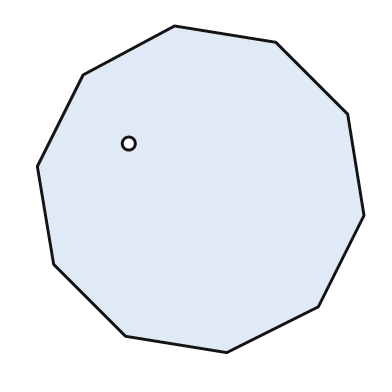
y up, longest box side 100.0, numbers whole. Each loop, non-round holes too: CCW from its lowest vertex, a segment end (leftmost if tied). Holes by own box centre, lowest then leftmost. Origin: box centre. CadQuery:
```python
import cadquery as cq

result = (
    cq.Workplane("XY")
    .moveTo(8.0, -50.0)
    .lineTo(36.0, -36.0)
    .lineTo(50.0, -8.0)
    .lineTo(45.0, 23.0)
    .lineTo(23.0, 45.0)
    .lineTo(-8.0, 50.0)
    .lineTo(-36.0, 35.0)
    .lineTo(-50.0, 7.0)
    .lineTo(-45.0, -23.0)
    .lineTo(-23.0, -45.0)
    .close()
    .moveTo(-22.0, 14.0)
    .circle(2.0)
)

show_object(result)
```